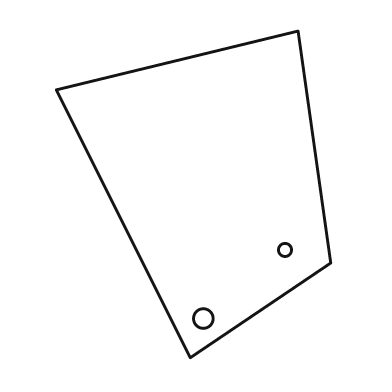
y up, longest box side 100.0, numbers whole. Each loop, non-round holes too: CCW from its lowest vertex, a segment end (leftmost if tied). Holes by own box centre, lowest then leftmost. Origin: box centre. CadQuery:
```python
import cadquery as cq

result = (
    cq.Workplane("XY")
    .moveTo(-1.0, -50.0)
    .lineTo(42.0, -21.0)
    .lineTo(32.0, 50.0)
    .lineTo(-42.0, 32.0)
    .close()
    .moveTo(3.0, -38.0)
    .circle(3.0)
    .moveTo(28.0, -17.0)
    .circle(2.0)
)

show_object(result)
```